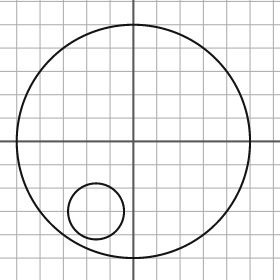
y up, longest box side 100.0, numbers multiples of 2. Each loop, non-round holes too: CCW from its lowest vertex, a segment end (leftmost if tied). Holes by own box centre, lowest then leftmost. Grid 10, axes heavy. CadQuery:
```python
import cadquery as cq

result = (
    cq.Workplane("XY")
    .moveTo(0.0, 0.0)
    .circle(50.0)
    .moveTo(-16.0, -30.0)
    .circle(12.0)
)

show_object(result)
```